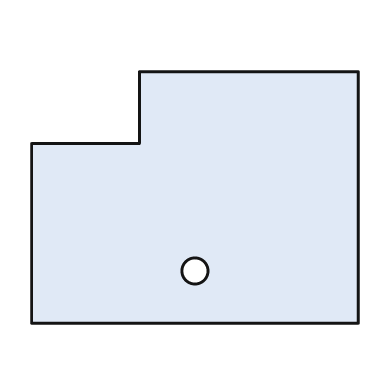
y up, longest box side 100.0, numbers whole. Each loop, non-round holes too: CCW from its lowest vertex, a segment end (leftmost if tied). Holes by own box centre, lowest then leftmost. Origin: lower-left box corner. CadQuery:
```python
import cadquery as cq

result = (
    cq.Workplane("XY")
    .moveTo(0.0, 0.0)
    .lineTo(100.0, 0.0)
    .lineTo(100.0, 77.0)
    .lineTo(33.0, 77.0)
    .lineTo(33.0, 55.0)
    .lineTo(0.0, 55.0)
    .close()
    .moveTo(50.0, 16.0)
    .circle(4.0)
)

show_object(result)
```